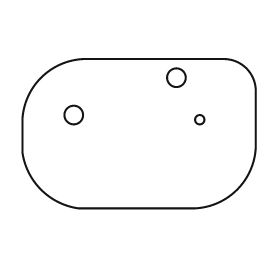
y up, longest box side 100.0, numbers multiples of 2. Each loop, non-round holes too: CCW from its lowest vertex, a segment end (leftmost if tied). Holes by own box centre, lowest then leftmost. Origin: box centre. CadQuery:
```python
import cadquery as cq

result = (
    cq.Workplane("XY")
    .moveTo(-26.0, -32.0)
    .lineTo(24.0, -32.0)
    .threePointArc((42.0, -24.0), (50.0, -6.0))
    .lineTo(50.0, 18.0)
    .threePointArc((46.0, 28.0), (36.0, 32.0))
    .lineTo(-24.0, 32.0)
    .threePointArc((-42.0, 24.0), (-50.0, 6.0))
    .lineTo(-50.0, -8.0)
    .threePointArc((-42.0, -24.0), (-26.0, -32.0))
    .close()
    .moveTo(26.0, 6.0)
    .circle(2.0)
    .moveTo(-28.0, 8.0)
    .circle(4.0)
    .moveTo(16.0, 24.0)
    .circle(4.0)
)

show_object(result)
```